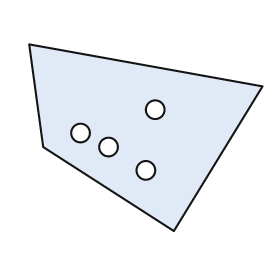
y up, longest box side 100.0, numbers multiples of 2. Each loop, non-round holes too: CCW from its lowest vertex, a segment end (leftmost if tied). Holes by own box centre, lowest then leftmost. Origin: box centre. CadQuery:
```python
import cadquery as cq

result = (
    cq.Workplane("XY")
    .moveTo(12.0, -40.0)
    .lineTo(50.0, 22.0)
    .lineTo(-50.0, 40.0)
    .lineTo(-44.0, -4.0)
    .close()
    .moveTo(0.0, -14.0)
    .circle(4.0)
    .moveTo(-16.0, -4.0)
    .circle(4.0)
    .moveTo(-28.0, 2.0)
    .circle(4.0)
    .moveTo(4.0, 12.0)
    .circle(4.0)
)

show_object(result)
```